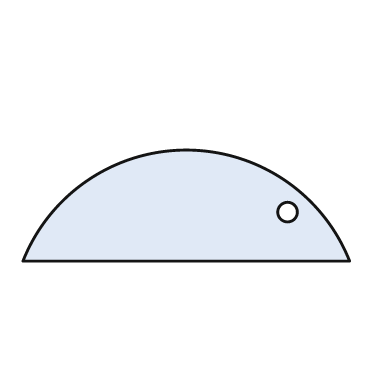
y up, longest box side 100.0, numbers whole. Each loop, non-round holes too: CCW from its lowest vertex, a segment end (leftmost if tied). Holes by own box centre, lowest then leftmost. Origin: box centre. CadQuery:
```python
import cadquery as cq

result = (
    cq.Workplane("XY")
    .moveTo(-50.0, -17.0)
    .lineTo(50.0, -17.0)
    .threePointArc((0.0, 17.0), (-50.0, -17.0))
    .close()
    .moveTo(31.0, -2.0)
    .circle(3.0)
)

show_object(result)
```